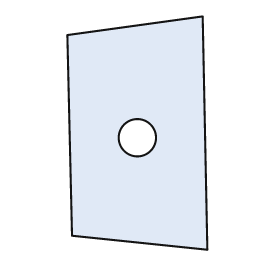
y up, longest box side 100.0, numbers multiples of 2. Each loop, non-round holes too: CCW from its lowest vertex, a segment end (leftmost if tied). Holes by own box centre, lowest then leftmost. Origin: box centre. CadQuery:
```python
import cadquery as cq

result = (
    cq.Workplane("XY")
    .moveTo(30.0, -50.0)
    .lineTo(28.0, 50.0)
    .lineTo(-30.0, 42.0)
    .lineTo(-28.0, -44.0)
    .close()
    .moveTo(0.0, -2.0)
    .circle(8.0)
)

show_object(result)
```